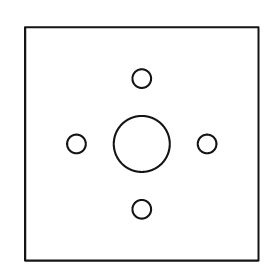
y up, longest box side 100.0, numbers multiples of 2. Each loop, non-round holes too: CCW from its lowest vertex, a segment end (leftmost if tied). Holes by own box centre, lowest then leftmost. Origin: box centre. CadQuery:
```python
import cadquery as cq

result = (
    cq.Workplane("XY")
    .moveTo(-50.0, -50.0)
    .lineTo(50.0, -50.0)
    .lineTo(50.0, 50.0)
    .lineTo(-50.0, 50.0)
    .close()
    .moveTo(0.0, -28.0)
    .circle(4.0)
    .moveTo(-28.0, 0.0)
    .circle(4.0)
    .moveTo(0.0, 0.0)
    .circle(12.0)
    .moveTo(28.0, 0.0)
    .circle(4.0)
    .moveTo(0.0, 28.0)
    .circle(4.0)
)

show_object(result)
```